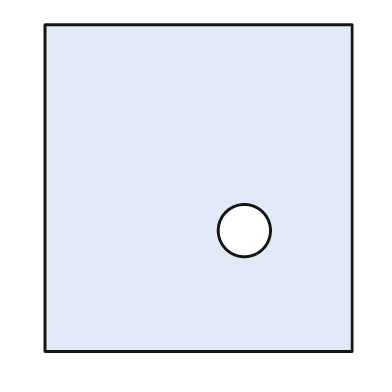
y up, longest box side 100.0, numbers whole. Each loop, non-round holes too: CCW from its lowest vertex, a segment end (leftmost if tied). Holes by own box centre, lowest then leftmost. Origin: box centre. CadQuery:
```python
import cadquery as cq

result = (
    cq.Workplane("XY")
    .moveTo(-47.0, -50.0)
    .lineTo(47.0, -50.0)
    .lineTo(47.0, 50.0)
    .lineTo(-47.0, 50.0)
    .close()
    .moveTo(14.0, -13.0)
    .circle(8.0)
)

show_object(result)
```